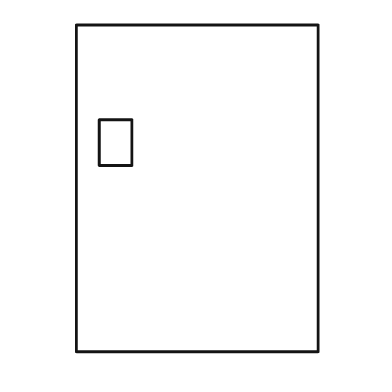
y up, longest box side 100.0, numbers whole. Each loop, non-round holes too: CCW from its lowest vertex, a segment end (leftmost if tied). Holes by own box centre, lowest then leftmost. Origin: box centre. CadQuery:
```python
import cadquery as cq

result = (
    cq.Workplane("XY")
    .moveTo(-37.0, -50.0)
    .lineTo(37.0, -50.0)
    .lineTo(37.0, 50.0)
    .lineTo(-37.0, 50.0)
    .close()
    .moveTo(-30.0, 7.0)
    .lineTo(-20.0, 7.0)
    .lineTo(-20.0, 21.0)
    .lineTo(-30.0, 21.0)
    .close()
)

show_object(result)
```